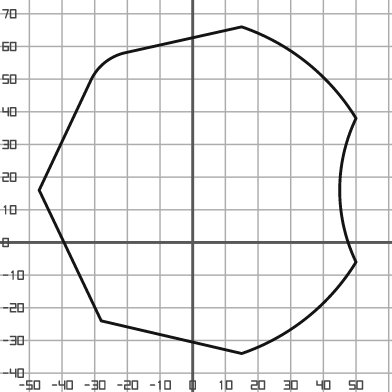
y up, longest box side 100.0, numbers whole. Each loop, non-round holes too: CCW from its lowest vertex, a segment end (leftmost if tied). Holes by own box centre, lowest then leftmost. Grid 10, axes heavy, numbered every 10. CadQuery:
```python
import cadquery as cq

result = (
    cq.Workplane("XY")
    .moveTo(15.0, -34.0)
    .threePointArc((35.0, -23.0), (50.0, -6.0))
    .threePointArc((45.0, 16.0), (50.0, 38.0))
    .threePointArc((35.0, 55.0), (15.0, 66.0))
    .lineTo(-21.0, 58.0)
    .threePointArc((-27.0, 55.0), (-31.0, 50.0))
    .lineTo(-47.0, 16.0)
    .lineTo(-28.0, -24.0)
    .close()
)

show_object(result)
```